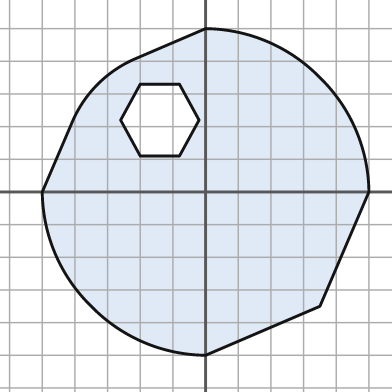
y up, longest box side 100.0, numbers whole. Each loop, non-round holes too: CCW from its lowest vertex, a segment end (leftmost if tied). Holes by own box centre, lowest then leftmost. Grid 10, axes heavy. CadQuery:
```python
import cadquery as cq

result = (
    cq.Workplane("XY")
    .moveTo(0.0, -50.0)
    .lineTo(35.0, -35.0)
    .lineTo(50.0, 0.0)
    .threePointArc((46.0, 19.0), (35.0, 35.0))
    .threePointArc((19.0, 46.0), (0.0, 50.0))
    .lineTo(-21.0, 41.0)
    .threePointArc((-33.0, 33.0), (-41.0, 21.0))
    .lineTo(-50.0, 0.0)
    .threePointArc((-46.0, -19.0), (-35.0, -35.0))
    .threePointArc((-19.0, -46.0), (0.0, -50.0))
    .close()
    .moveTo(-20.0, 11.0)
    .lineTo(-8.0, 11.0)
    .lineTo(-2.0, 22.0)
    .lineTo(-8.0, 33.0)
    .lineTo(-20.0, 33.0)
    .lineTo(-26.0, 22.0)
    .close()
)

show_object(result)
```